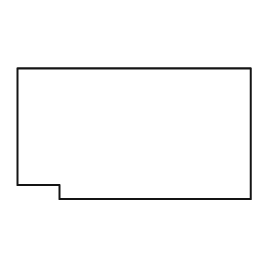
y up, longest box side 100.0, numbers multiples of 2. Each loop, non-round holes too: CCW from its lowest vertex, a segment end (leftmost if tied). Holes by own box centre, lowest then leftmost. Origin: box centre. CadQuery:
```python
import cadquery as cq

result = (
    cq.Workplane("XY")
    .moveTo(-32.0, -28.0)
    .lineTo(50.0, -28.0)
    .lineTo(50.0, 28.0)
    .lineTo(-50.0, 28.0)
    .lineTo(-50.0, -22.0)
    .lineTo(-32.0, -22.0)
    .close()
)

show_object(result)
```